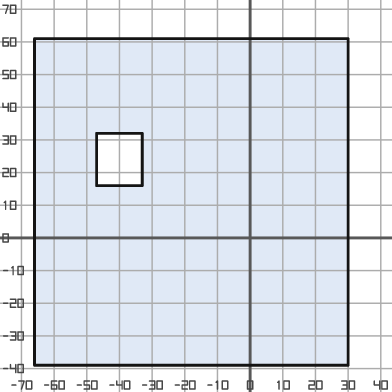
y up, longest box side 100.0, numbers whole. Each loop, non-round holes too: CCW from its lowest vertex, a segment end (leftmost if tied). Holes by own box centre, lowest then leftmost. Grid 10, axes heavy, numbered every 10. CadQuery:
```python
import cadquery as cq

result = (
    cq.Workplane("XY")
    .moveTo(-66.0, -39.0)
    .lineTo(30.0, -39.0)
    .lineTo(30.0, 61.0)
    .lineTo(-66.0, 61.0)
    .close()
    .moveTo(-47.0, 16.0)
    .lineTo(-33.0, 16.0)
    .lineTo(-33.0, 32.0)
    .lineTo(-47.0, 32.0)
    .close()
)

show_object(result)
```